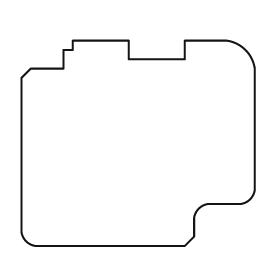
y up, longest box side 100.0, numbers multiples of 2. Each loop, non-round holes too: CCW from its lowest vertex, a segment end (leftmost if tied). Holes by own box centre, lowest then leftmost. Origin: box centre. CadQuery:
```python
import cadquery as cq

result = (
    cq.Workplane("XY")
    .moveTo(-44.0, -44.0)
    .lineTo(20.0, -44.0)
    .lineTo(24.0, -40.0)
    .lineTo(24.0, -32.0)
    .threePointArc((26.0, -28.0), (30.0, -26.0))
    .lineTo(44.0, -26.0)
    .threePointArc((48.0, -24.0), (50.0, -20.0))
    .lineTo(50.0, 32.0)
    .threePointArc((46.0, 40.0), (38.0, 44.0))
    .lineTo(20.0, 44.0)
    .lineTo(20.0, 36.0)
    .lineTo(-4.0, 36.0)
    .lineTo(-4.0, 44.0)
    .lineTo(-28.0, 44.0)
    .lineTo(-28.0, 40.0)
    .lineTo(-32.0, 40.0)
    .lineTo(-32.0, 32.0)
    .lineTo(-46.0, 32.0)
    .lineTo(-50.0, 28.0)
    .lineTo(-50.0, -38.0)
    .threePointArc((-48.0, -42.0), (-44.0, -44.0))
    .close()
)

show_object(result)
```